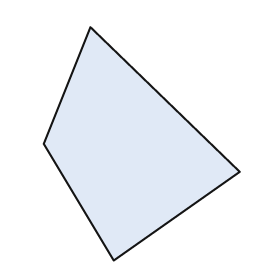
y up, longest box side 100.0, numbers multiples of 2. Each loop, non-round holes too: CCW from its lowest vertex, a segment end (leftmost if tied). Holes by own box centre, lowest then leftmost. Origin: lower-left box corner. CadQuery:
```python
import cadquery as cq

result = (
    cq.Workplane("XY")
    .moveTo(30.0, 0.0)
    .lineTo(84.0, 38.0)
    .lineTo(20.0, 100.0)
    .lineTo(0.0, 50.0)
    .close()
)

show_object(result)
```